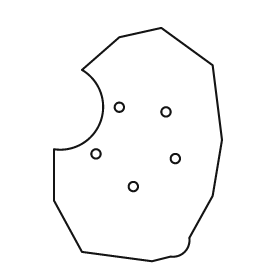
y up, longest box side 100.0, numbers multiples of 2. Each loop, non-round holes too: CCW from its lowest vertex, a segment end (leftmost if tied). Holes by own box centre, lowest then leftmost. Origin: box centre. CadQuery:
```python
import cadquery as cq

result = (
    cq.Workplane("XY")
    .moveTo(6.0, -50.0)
    .lineTo(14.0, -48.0)
    .threePointArc((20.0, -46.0), (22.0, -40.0))
    .lineTo(32.0, -22.0)
    .lineTo(36.0, 2.0)
    .lineTo(32.0, 34.0)
    .lineTo(10.0, 50.0)
    .lineTo(-8.0, 46.0)
    .lineTo(-24.0, 32.0)
    .threePointArc((-16.0, 10.0), (-36.0, -2.0))
    .lineTo(-36.0, -24.0)
    .lineTo(-24.0, -46.0)
    .close()
    .moveTo(-2.0, -18.0)
    .circle(2.0)
    .moveTo(16.0, -6.0)
    .circle(2.0)
    .moveTo(-18.0, -4.0)
    .circle(2.0)
    .moveTo(12.0, 14.0)
    .circle(2.0)
    .moveTo(-8.0, 16.0)
    .circle(2.0)
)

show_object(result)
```